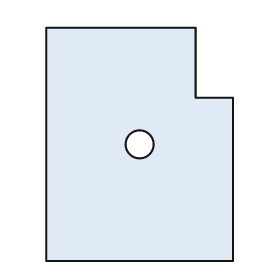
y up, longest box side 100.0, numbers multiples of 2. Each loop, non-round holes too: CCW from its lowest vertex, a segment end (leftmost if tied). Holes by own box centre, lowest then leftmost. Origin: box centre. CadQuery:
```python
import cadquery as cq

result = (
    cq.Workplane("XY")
    .moveTo(-40.0, -50.0)
    .lineTo(40.0, -50.0)
    .lineTo(40.0, 20.0)
    .lineTo(24.0, 20.0)
    .lineTo(24.0, 50.0)
    .lineTo(-40.0, 50.0)
    .close()
    .moveTo(0.0, 0.0)
    .circle(6.0)
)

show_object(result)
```